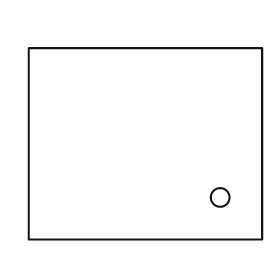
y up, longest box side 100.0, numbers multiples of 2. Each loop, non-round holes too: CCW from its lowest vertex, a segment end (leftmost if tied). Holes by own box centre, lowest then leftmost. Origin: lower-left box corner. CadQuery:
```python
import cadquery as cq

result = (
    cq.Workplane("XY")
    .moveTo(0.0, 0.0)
    .lineTo(100.0, 0.0)
    .lineTo(100.0, 82.0)
    .lineTo(0.0, 82.0)
    .close()
    .moveTo(82.0, 18.0)
    .circle(4.0)
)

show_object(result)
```